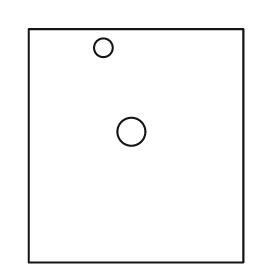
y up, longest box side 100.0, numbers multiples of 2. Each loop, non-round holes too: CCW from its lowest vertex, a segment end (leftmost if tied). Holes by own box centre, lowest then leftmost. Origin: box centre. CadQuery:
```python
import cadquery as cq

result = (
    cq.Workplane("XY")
    .moveTo(-46.0, -50.0)
    .lineTo(46.0, -50.0)
    .lineTo(46.0, 50.0)
    .lineTo(-46.0, 50.0)
    .close()
    .moveTo(-2.0, 6.0)
    .circle(6.0)
    .moveTo(-14.0, 42.0)
    .circle(4.0)
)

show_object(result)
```